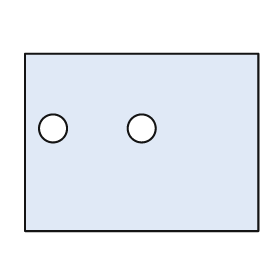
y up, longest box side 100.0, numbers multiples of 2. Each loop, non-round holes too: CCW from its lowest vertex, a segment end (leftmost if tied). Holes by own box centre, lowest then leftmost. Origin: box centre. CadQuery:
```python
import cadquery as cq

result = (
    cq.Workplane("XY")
    .moveTo(-50.0, -38.0)
    .lineTo(50.0, -38.0)
    .lineTo(50.0, 38.0)
    .lineTo(-50.0, 38.0)
    .close()
    .moveTo(-38.0, 6.0)
    .circle(6.0)
    .moveTo(0.0, 6.0)
    .circle(6.0)
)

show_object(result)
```